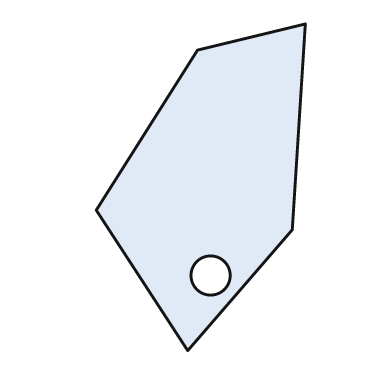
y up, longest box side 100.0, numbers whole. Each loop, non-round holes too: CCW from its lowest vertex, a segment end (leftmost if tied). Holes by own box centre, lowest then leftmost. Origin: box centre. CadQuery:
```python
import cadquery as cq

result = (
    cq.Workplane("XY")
    .moveTo(-4.0, -50.0)
    .lineTo(28.0, -13.0)
    .lineTo(32.0, 50.0)
    .lineTo(-1.0, 42.0)
    .lineTo(-32.0, -7.0)
    .close()
    .moveTo(3.0, -27.0)
    .circle(6.0)
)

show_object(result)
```